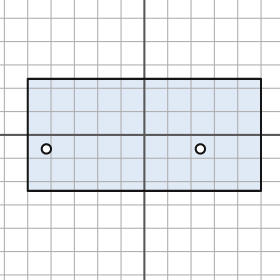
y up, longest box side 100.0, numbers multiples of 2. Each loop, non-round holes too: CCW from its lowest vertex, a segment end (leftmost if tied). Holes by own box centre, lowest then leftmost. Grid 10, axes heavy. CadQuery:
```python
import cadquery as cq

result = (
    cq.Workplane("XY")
    .moveTo(-50.0, -24.0)
    .lineTo(50.0, -24.0)
    .lineTo(50.0, 24.0)
    .lineTo(-50.0, 24.0)
    .close()
    .moveTo(-42.0, -6.0)
    .circle(2.0)
    .moveTo(24.0, -6.0)
    .circle(2.0)
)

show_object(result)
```